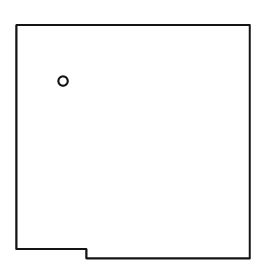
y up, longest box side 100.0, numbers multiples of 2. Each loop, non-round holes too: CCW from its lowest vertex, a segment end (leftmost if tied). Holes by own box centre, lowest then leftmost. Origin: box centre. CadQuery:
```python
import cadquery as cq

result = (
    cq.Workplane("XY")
    .moveTo(-20.0, -50.0)
    .lineTo(50.0, -50.0)
    .lineTo(50.0, 50.0)
    .lineTo(-50.0, 50.0)
    .lineTo(-50.0, -46.0)
    .lineTo(-20.0, -46.0)
    .close()
    .moveTo(-30.0, 26.0)
    .circle(2.0)
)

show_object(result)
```